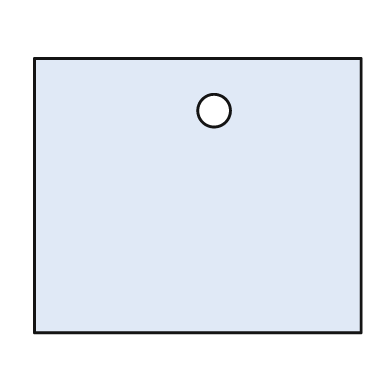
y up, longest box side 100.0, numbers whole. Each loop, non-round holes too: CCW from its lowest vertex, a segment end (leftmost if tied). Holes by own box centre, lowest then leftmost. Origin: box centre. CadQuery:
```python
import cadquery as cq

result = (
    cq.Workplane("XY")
    .moveTo(-50.0, -42.0)
    .lineTo(50.0, -42.0)
    .lineTo(50.0, 42.0)
    .lineTo(-50.0, 42.0)
    .close()
    .moveTo(5.0, 26.0)
    .circle(5.0)
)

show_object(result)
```